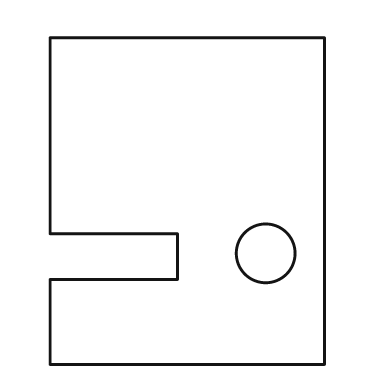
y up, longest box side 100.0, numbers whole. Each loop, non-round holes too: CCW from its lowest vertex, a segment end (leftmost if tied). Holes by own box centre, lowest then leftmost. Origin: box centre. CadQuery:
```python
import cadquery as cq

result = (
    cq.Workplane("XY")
    .moveTo(-42.0, -50.0)
    .lineTo(42.0, -50.0)
    .lineTo(42.0, 50.0)
    .lineTo(-42.0, 50.0)
    .lineTo(-42.0, -10.0)
    .lineTo(-3.0, -10.0)
    .lineTo(-3.0, -24.0)
    .lineTo(-42.0, -24.0)
    .close()
    .moveTo(24.0, -16.0)
    .circle(9.0)
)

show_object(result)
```